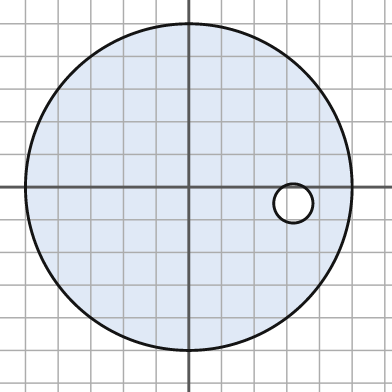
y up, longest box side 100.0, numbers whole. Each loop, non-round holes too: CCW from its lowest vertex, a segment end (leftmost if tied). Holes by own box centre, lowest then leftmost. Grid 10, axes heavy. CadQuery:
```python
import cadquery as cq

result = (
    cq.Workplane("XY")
    .moveTo(0.0, 0.0)
    .circle(50.0)
    .moveTo(32.0, -5.0)
    .circle(6.0)
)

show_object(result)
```